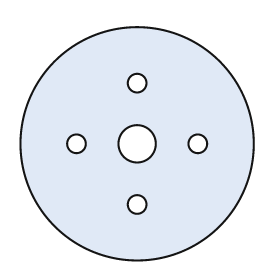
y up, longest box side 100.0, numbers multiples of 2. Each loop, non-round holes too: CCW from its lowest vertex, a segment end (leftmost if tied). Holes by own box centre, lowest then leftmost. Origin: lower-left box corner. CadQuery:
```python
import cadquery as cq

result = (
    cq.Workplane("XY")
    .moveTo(50.0, 50.0)
    .circle(50.0)
    .moveTo(50.0, 24.0)
    .circle(4.0)
    .moveTo(24.0, 50.0)
    .circle(4.0)
    .moveTo(50.0, 50.0)
    .circle(8.0)
    .moveTo(76.0, 50.0)
    .circle(4.0)
    .moveTo(50.0, 76.0)
    .circle(4.0)
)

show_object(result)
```